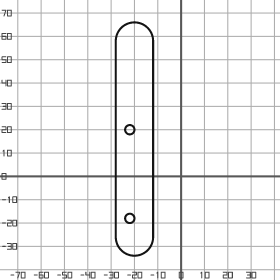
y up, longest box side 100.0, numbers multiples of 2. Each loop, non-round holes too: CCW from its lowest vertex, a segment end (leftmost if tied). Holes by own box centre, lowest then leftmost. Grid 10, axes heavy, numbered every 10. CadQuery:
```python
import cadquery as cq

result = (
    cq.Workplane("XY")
    .moveTo(-28.0, -26.0)
    .threePointArc((-20.0, -34.0), (-12.0, -26.0))
    .lineTo(-12.0, 58.0)
    .threePointArc((-20.0, 66.0), (-28.0, 58.0))
    .close()
    .moveTo(-22.0, -18.0)
    .circle(2.0)
    .moveTo(-22.0, 20.0)
    .circle(2.0)
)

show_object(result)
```